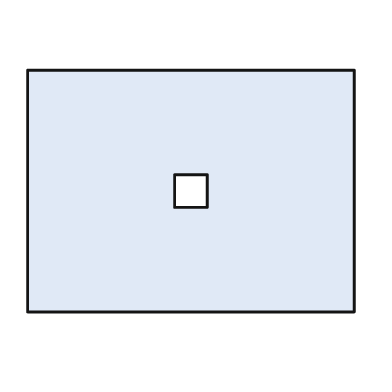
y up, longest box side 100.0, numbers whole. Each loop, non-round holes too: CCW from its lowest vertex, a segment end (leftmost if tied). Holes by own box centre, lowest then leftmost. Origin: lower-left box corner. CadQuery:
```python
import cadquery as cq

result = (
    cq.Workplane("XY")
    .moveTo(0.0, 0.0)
    .lineTo(100.0, 0.0)
    .lineTo(100.0, 74.0)
    .lineTo(0.0, 74.0)
    .close()
    .moveTo(45.0, 32.0)
    .lineTo(55.0, 32.0)
    .lineTo(55.0, 42.0)
    .lineTo(45.0, 42.0)
    .close()
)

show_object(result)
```